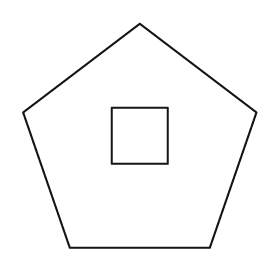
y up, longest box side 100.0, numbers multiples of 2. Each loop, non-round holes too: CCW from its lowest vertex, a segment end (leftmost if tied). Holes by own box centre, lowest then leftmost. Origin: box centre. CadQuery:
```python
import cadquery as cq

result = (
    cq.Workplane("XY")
    .moveTo(-30.0, -48.0)
    .lineTo(30.0, -48.0)
    .lineTo(50.0, 10.0)
    .lineTo(0.0, 48.0)
    .lineTo(-50.0, 10.0)
    .close()
    .moveTo(-12.0, -12.0)
    .lineTo(12.0, -12.0)
    .lineTo(12.0, 12.0)
    .lineTo(-12.0, 12.0)
    .close()
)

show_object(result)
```